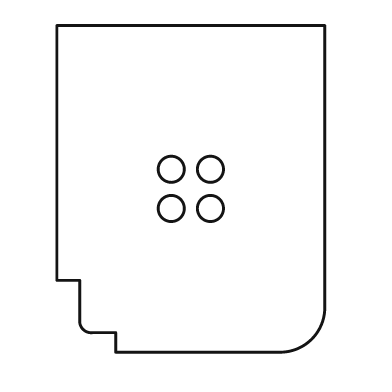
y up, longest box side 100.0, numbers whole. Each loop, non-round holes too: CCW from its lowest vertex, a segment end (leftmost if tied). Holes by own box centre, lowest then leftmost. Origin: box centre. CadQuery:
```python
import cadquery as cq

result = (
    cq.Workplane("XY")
    .moveTo(-23.0, -50.0)
    .lineTo(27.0, -50.0)
    .threePointArc((37.0, -46.0), (41.0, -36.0))
    .lineTo(41.0, 50.0)
    .lineTo(-41.0, 50.0)
    .lineTo(-41.0, -28.0)
    .lineTo(-34.0, -28.0)
    .lineTo(-34.0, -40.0)
    .threePointArc((-33.0, -43.0), (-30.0, -44.0))
    .lineTo(-23.0, -44.0)
    .close()
    .moveTo(-6.0, -6.0)
    .circle(4.0)
    .moveTo(6.0, -6.0)
    .circle(4.0)
    .moveTo(-6.0, 6.0)
    .circle(4.0)
    .moveTo(6.0, 6.0)
    .circle(4.0)
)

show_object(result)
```